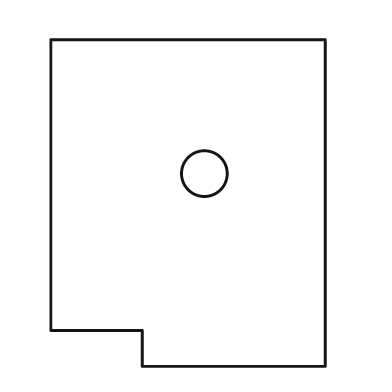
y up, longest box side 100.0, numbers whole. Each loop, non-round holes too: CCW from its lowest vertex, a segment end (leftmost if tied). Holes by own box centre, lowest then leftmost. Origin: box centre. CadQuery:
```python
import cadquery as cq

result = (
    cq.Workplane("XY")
    .moveTo(-14.0, -50.0)
    .lineTo(42.0, -50.0)
    .lineTo(42.0, 50.0)
    .lineTo(-42.0, 50.0)
    .lineTo(-42.0, -39.0)
    .lineTo(-14.0, -39.0)
    .close()
    .moveTo(5.0, 9.0)
    .circle(7.0)
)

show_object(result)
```